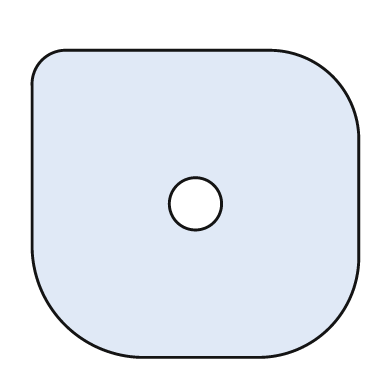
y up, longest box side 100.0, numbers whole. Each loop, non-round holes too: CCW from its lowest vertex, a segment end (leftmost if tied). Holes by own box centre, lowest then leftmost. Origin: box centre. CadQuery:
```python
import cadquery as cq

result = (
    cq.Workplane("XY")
    .moveTo(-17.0, -47.0)
    .lineTo(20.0, -47.0)
    .threePointArc((41.0, -38.0), (50.0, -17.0))
    .lineTo(50.0, 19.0)
    .threePointArc((42.0, 39.0), (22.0, 47.0))
    .lineTo(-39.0, 47.0)
    .threePointArc((-47.0, 44.0), (-50.0, 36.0))
    .lineTo(-50.0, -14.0)
    .threePointArc((-40.0, -37.0), (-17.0, -47.0))
    .close()
    .moveTo(0.0, 0.0)
    .circle(8.0)
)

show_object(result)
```